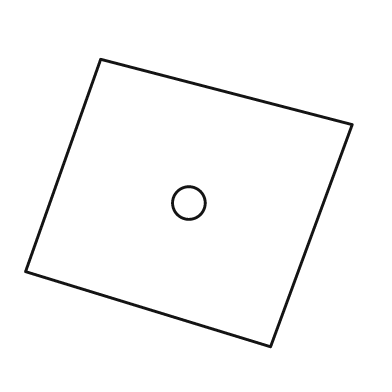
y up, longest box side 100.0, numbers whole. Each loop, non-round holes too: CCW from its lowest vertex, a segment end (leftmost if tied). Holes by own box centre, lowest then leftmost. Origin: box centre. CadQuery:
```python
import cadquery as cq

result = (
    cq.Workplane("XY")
    .moveTo(25.0, -44.0)
    .lineTo(50.0, 24.0)
    .lineTo(-27.0, 44.0)
    .lineTo(-50.0, -21.0)
    .close()
    .moveTo(0.0, 0.0)
    .circle(5.0)
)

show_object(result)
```